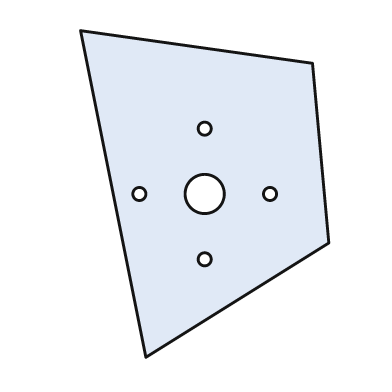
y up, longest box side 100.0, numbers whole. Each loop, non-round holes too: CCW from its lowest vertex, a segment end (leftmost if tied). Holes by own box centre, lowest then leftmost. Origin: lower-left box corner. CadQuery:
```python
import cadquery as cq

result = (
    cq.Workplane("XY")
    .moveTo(20.0, 0.0)
    .lineTo(76.0, 35.0)
    .lineTo(71.0, 90.0)
    .lineTo(0.0, 100.0)
    .close()
    .moveTo(38.0, 30.0)
    .circle(2.0)
    .moveTo(18.0, 50.0)
    .circle(2.0)
    .moveTo(38.0, 50.0)
    .circle(6.0)
    .moveTo(58.0, 50.0)
    .circle(2.0)
    .moveTo(38.0, 70.0)
    .circle(2.0)
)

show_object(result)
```